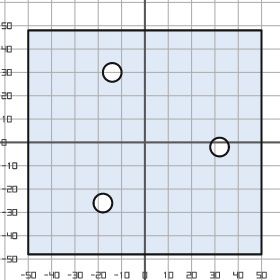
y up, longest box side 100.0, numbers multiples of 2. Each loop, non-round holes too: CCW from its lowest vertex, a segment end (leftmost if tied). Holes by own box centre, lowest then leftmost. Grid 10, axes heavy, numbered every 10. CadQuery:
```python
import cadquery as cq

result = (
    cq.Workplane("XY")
    .moveTo(-50.0, -48.0)
    .lineTo(50.0, -48.0)
    .lineTo(50.0, 48.0)
    .lineTo(-50.0, 48.0)
    .close()
    .moveTo(-18.0, -26.0)
    .circle(4.0)
    .moveTo(32.0, -2.0)
    .circle(4.0)
    .moveTo(-14.0, 30.0)
    .circle(4.0)
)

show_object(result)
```